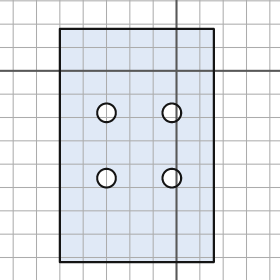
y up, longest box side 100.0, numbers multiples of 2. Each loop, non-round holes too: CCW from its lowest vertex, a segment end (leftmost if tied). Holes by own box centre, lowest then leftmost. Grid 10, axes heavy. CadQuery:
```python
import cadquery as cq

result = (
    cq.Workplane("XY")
    .moveTo(-50.0, -82.0)
    .lineTo(16.0, -82.0)
    .lineTo(16.0, 18.0)
    .lineTo(-50.0, 18.0)
    .close()
    .moveTo(-30.0, -46.0)
    .circle(4.0)
    .moveTo(-2.0, -46.0)
    .circle(4.0)
    .moveTo(-30.0, -18.0)
    .circle(4.0)
    .moveTo(-2.0, -18.0)
    .circle(4.0)
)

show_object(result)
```